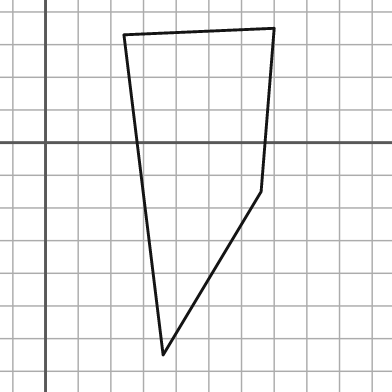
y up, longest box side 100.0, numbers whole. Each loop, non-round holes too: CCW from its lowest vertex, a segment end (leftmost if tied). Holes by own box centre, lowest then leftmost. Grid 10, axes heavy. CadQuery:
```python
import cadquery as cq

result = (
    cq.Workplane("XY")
    .moveTo(36.0, -65.0)
    .lineTo(66.0, -15.0)
    .lineTo(70.0, 35.0)
    .lineTo(24.0, 33.0)
    .close()
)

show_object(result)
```